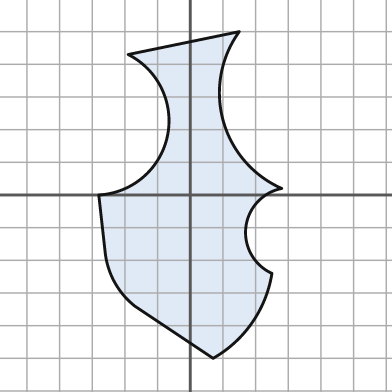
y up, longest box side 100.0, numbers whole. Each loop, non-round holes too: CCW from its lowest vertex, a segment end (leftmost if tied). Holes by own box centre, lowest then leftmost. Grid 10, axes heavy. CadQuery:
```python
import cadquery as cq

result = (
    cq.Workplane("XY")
    .moveTo(7.0, -50.0)
    .threePointArc((19.0, -39.0), (25.0, -24.0))
    .threePointArc((17.0, -10.0), (28.0, 2.0))
    .threePointArc((10.0, 23.0), (15.0, 50.0))
    .lineTo(-19.0, 43.0)
    .threePointArc((-7.0, 18.0), (-28.0, 0.0))
    .lineTo(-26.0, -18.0)
    .threePointArc((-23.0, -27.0), (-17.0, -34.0))
    .close()
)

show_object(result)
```